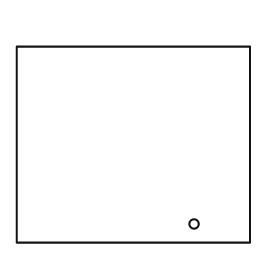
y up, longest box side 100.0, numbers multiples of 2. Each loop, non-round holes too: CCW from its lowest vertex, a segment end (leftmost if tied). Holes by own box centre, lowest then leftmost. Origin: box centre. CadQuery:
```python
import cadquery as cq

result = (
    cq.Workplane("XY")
    .moveTo(-50.0, -42.0)
    .lineTo(50.0, -42.0)
    .lineTo(50.0, 42.0)
    .lineTo(-50.0, 42.0)
    .close()
    .moveTo(26.0, -34.0)
    .circle(2.0)
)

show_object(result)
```